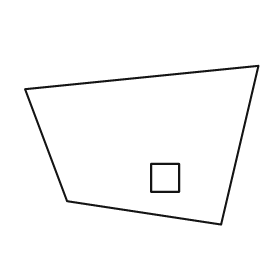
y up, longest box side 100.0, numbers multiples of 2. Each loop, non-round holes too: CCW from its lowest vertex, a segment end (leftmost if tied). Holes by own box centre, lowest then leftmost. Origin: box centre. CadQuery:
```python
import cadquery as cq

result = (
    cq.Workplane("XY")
    .moveTo(34.0, -34.0)
    .lineTo(50.0, 34.0)
    .lineTo(-50.0, 24.0)
    .lineTo(-32.0, -24.0)
    .close()
    .moveTo(4.0, -20.0)
    .lineTo(16.0, -20.0)
    .lineTo(16.0, -8.0)
    .lineTo(4.0, -8.0)
    .close()
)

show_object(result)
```